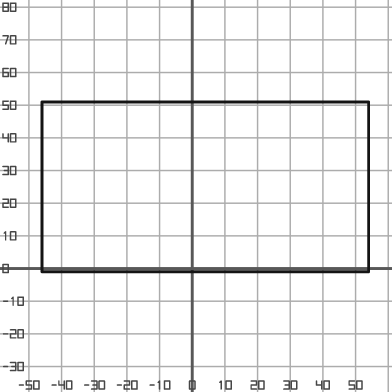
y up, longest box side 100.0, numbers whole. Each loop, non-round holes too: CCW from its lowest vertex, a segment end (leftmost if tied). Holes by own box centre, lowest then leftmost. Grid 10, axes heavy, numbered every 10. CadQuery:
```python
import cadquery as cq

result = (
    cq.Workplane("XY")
    .moveTo(-46.0, -1.0)
    .lineTo(54.0, -1.0)
    .lineTo(54.0, 51.0)
    .lineTo(-46.0, 51.0)
    .close()
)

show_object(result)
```